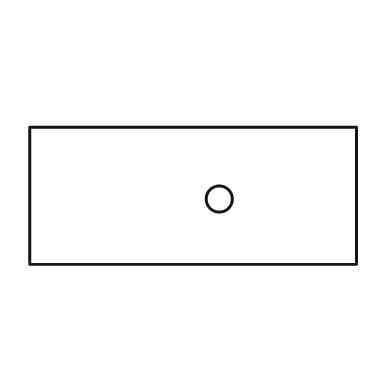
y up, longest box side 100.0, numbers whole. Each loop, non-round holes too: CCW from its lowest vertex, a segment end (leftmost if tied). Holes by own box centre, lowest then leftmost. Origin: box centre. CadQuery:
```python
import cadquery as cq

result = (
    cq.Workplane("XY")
    .moveTo(-50.0, -21.0)
    .lineTo(50.0, -21.0)
    .lineTo(50.0, 21.0)
    .lineTo(-50.0, 21.0)
    .close()
    .moveTo(8.0, -1.0)
    .circle(4.0)
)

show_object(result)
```